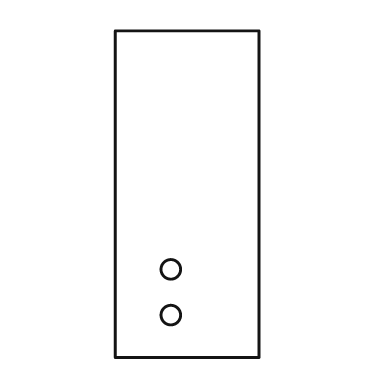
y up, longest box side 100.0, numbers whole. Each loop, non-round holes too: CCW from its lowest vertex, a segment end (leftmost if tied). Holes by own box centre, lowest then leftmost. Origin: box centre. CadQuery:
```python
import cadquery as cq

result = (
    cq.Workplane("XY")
    .moveTo(-22.0, -50.0)
    .lineTo(22.0, -50.0)
    .lineTo(22.0, 50.0)
    .lineTo(-22.0, 50.0)
    .close()
    .moveTo(-5.0, -37.0)
    .circle(3.0)
    .moveTo(-5.0, -23.0)
    .circle(3.0)
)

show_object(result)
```